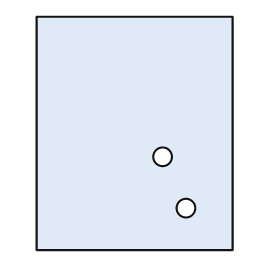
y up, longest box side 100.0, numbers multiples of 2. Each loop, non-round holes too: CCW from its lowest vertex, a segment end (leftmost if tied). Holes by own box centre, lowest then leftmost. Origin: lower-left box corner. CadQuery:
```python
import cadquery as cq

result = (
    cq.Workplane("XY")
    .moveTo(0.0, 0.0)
    .lineTo(84.0, 0.0)
    .lineTo(84.0, 100.0)
    .lineTo(0.0, 100.0)
    .close()
    .moveTo(64.0, 18.0)
    .circle(4.0)
    .moveTo(54.0, 40.0)
    .circle(4.0)
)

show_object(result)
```